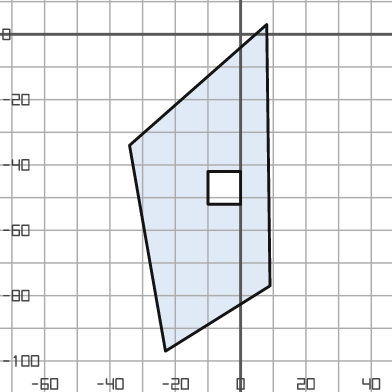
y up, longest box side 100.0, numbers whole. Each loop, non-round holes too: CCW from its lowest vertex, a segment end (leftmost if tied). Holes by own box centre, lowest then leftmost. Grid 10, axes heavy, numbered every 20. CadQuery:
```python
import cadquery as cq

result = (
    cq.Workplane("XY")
    .moveTo(-23.0, -97.0)
    .lineTo(9.0, -77.0)
    .lineTo(8.0, 3.0)
    .lineTo(-34.0, -34.0)
    .close()
    .moveTo(-10.0, -52.0)
    .lineTo(0.0, -52.0)
    .lineTo(0.0, -42.0)
    .lineTo(-10.0, -42.0)
    .close()
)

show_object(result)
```